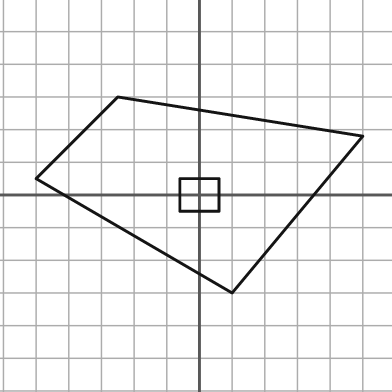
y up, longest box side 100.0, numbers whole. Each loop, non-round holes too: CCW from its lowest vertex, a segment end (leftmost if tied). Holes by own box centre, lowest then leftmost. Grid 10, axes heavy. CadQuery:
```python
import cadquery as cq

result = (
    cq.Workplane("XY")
    .moveTo(10.0, -30.0)
    .lineTo(50.0, 18.0)
    .lineTo(-25.0, 30.0)
    .lineTo(-50.0, 5.0)
    .close()
    .moveTo(-6.0, -5.0)
    .lineTo(6.0, -5.0)
    .lineTo(6.0, 5.0)
    .lineTo(-6.0, 5.0)
    .close()
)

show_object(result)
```